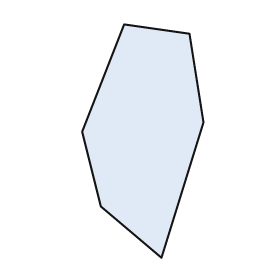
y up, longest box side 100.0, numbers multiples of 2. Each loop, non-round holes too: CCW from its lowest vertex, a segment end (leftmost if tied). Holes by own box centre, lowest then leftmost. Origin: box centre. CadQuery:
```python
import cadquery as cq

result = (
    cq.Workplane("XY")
    .moveTo(8.0, -50.0)
    .lineTo(26.0, 8.0)
    .lineTo(20.0, 46.0)
    .lineTo(-8.0, 50.0)
    .lineTo(-26.0, 4.0)
    .lineTo(-18.0, -28.0)
    .close()
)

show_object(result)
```